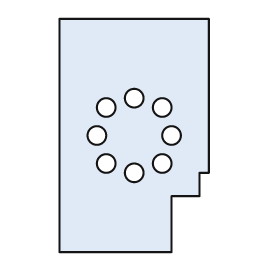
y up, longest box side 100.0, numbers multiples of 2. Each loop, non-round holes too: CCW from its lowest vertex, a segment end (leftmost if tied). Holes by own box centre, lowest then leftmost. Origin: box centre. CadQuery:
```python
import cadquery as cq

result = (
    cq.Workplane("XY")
    .moveTo(-32.0, -50.0)
    .lineTo(16.0, -50.0)
    .lineTo(16.0, -26.0)
    .lineTo(28.0, -26.0)
    .lineTo(28.0, -16.0)
    .lineTo(32.0, -16.0)
    .lineTo(32.0, 50.0)
    .lineTo(-32.0, 50.0)
    .close()
    .moveTo(0.0, -16.0)
    .circle(4.0)
    .moveTo(-12.0, -12.0)
    .circle(4.0)
    .moveTo(12.0, -12.0)
    .circle(4.0)
    .moveTo(-16.0, 0.0)
    .circle(4.0)
    .moveTo(16.0, 0.0)
    .circle(4.0)
    .moveTo(-12.0, 12.0)
    .circle(4.0)
    .moveTo(12.0, 12.0)
    .circle(4.0)
    .moveTo(0.0, 16.0)
    .circle(4.0)
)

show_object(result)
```